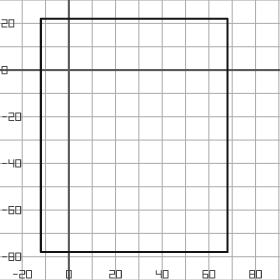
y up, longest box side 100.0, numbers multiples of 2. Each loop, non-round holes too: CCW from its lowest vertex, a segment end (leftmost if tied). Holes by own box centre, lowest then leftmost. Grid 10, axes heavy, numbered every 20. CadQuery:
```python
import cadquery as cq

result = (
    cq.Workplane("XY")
    .moveTo(-12.0, -78.0)
    .lineTo(68.0, -78.0)
    .lineTo(68.0, 22.0)
    .lineTo(-12.0, 22.0)
    .close()
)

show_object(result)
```